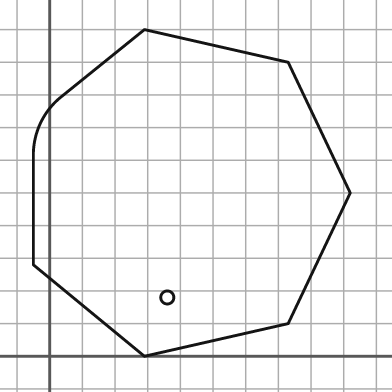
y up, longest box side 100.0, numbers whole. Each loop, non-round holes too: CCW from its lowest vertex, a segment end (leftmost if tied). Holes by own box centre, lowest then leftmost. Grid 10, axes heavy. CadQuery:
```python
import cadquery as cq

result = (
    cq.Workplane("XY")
    .moveTo(29.0, 0.0)
    .lineTo(73.0, 10.0)
    .lineTo(92.0, 50.0)
    .lineTo(73.0, 90.0)
    .lineTo(29.0, 100.0)
    .lineTo(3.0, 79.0)
    .threePointArc((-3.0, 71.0), (-5.0, 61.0))
    .lineTo(-5.0, 28.0)
    .close()
    .moveTo(36.0, 18.0)
    .circle(2.0)
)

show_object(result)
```